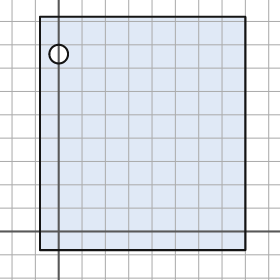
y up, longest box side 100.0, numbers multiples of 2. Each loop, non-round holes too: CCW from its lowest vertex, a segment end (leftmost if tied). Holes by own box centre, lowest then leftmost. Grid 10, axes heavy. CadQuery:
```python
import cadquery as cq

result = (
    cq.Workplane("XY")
    .moveTo(-8.0, -8.0)
    .lineTo(80.0, -8.0)
    .lineTo(80.0, 92.0)
    .lineTo(-8.0, 92.0)
    .close()
    .moveTo(0.0, 76.0)
    .circle(4.0)
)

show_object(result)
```